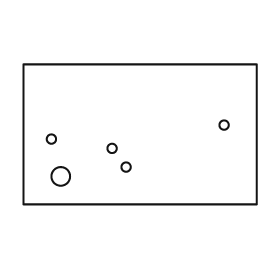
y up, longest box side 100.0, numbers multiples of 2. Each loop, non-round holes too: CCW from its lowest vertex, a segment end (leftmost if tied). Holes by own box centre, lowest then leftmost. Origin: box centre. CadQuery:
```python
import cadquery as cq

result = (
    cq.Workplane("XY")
    .moveTo(-50.0, -30.0)
    .lineTo(50.0, -30.0)
    .lineTo(50.0, 30.0)
    .lineTo(-50.0, 30.0)
    .close()
    .moveTo(-34.0, -18.0)
    .circle(4.0)
    .moveTo(-6.0, -14.0)
    .circle(2.0)
    .moveTo(-12.0, -6.0)
    .circle(2.0)
    .moveTo(-38.0, -2.0)
    .circle(2.0)
    .moveTo(36.0, 4.0)
    .circle(2.0)
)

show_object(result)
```